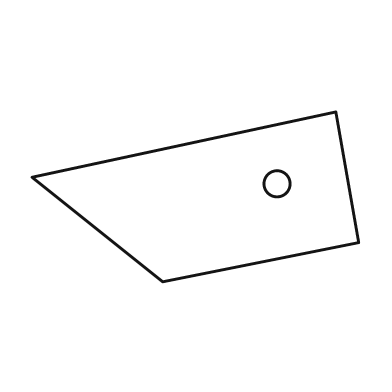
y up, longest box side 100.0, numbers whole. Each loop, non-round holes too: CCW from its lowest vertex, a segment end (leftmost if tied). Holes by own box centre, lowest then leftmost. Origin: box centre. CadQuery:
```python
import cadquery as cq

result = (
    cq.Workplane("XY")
    .moveTo(-10.0, -26.0)
    .lineTo(50.0, -14.0)
    .lineTo(43.0, 26.0)
    .lineTo(-50.0, 6.0)
    .close()
    .moveTo(25.0, 4.0)
    .circle(4.0)
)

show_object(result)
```